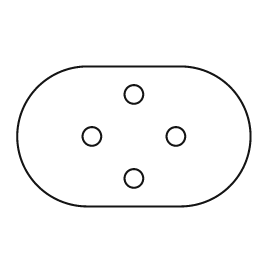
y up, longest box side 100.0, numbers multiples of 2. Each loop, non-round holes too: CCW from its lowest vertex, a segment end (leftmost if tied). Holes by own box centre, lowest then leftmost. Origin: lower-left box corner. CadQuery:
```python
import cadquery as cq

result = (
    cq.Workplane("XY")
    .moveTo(30.0, 0.0)
    .lineTo(70.0, 0.0)
    .threePointArc((100.0, 30.0), (70.0, 60.0))
    .lineTo(30.0, 60.0)
    .threePointArc((0.0, 30.0), (30.0, 0.0))
    .close()
    .moveTo(50.0, 12.0)
    .circle(4.0)
    .moveTo(32.0, 30.0)
    .circle(4.0)
    .moveTo(68.0, 30.0)
    .circle(4.0)
    .moveTo(50.0, 48.0)
    .circle(4.0)
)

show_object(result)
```